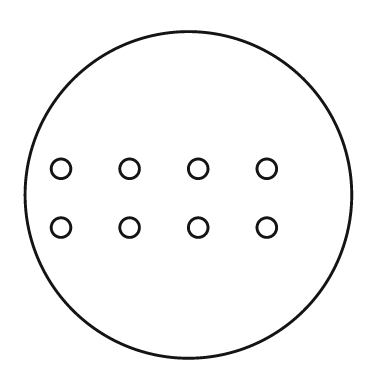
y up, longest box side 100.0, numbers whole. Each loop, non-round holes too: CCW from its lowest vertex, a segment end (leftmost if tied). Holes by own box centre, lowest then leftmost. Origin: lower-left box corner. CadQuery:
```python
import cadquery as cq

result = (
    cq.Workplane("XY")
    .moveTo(50.0, 50.0)
    .circle(50.0)
    .moveTo(11.0, 40.0)
    .circle(3.0)
    .moveTo(32.0, 40.0)
    .circle(3.0)
    .moveTo(53.0, 40.0)
    .circle(3.0)
    .moveTo(74.0, 40.0)
    .circle(3.0)
    .moveTo(11.0, 58.0)
    .circle(3.0)
    .moveTo(32.0, 58.0)
    .circle(3.0)
    .moveTo(53.0, 58.0)
    .circle(3.0)
    .moveTo(74.0, 58.0)
    .circle(3.0)
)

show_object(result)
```